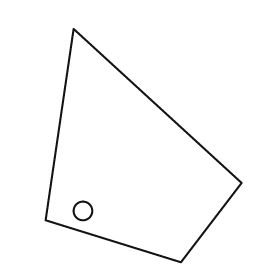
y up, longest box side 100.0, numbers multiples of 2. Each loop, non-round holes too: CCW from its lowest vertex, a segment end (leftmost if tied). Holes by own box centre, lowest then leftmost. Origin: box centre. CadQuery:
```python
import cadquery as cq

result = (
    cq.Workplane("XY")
    .moveTo(16.0, -50.0)
    .lineTo(42.0, -16.0)
    .lineTo(-30.0, 50.0)
    .lineTo(-42.0, -32.0)
    .close()
    .moveTo(-26.0, -28.0)
    .circle(4.0)
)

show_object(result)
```